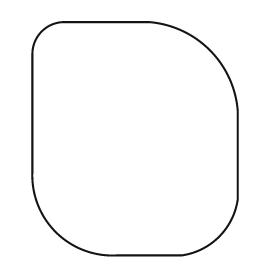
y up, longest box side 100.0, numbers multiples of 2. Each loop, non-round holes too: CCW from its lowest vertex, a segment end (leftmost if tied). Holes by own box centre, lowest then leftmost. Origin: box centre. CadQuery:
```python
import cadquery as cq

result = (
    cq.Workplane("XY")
    .moveTo(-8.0, -50.0)
    .lineTo(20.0, -50.0)
    .threePointArc((36.0, -42.0), (44.0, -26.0))
    .lineTo(44.0, 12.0)
    .threePointArc((32.0, 38.0), (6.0, 50.0))
    .lineTo(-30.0, 50.0)
    .threePointArc((-40.0, 46.0), (-44.0, 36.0))
    .lineTo(-44.0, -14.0)
    .threePointArc((-34.0, -40.0), (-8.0, -50.0))
    .close()
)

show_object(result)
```